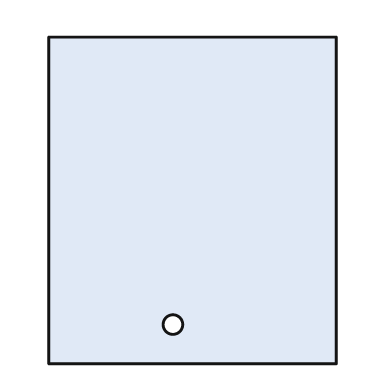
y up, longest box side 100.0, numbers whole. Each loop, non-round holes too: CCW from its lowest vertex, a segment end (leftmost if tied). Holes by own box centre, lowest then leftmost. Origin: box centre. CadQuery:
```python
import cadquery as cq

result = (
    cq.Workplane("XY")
    .moveTo(-44.0, -50.0)
    .lineTo(44.0, -50.0)
    .lineTo(44.0, 50.0)
    .lineTo(-44.0, 50.0)
    .close()
    .moveTo(-6.0, -38.0)
    .circle(3.0)
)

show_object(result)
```